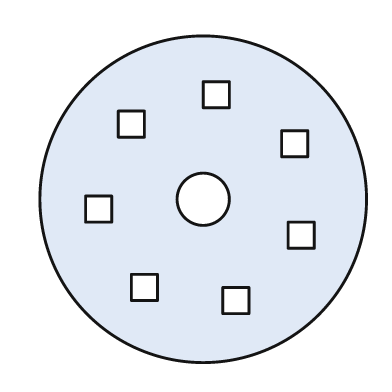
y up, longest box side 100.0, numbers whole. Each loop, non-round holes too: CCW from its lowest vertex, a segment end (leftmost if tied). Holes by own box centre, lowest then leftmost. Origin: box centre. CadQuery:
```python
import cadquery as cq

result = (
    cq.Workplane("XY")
    .moveTo(0.0, 0.0)
    .circle(50.0)
    .moveTo(6.0, -35.0)
    .lineTo(14.0, -35.0)
    .lineTo(14.0, -27.0)
    .lineTo(6.0, -27.0)
    .close()
    .moveTo(-22.0, -31.0)
    .lineTo(-14.0, -31.0)
    .lineTo(-14.0, -23.0)
    .lineTo(-22.0, -23.0)
    .close()
    .moveTo(26.0, -15.0)
    .lineTo(34.0, -15.0)
    .lineTo(34.0, -7.0)
    .lineTo(26.0, -7.0)
    .close()
    .moveTo(-36.0, -7.0)
    .lineTo(-28.0, -7.0)
    .lineTo(-28.0, 1.0)
    .lineTo(-36.0, 1.0)
    .close()
    .moveTo(0.0, 0.0)
    .circle(8.0)
    .moveTo(24.0, 13.0)
    .lineTo(32.0, 13.0)
    .lineTo(32.0, 21.0)
    .lineTo(24.0, 21.0)
    .close()
    .moveTo(-26.0, 19.0)
    .lineTo(-18.0, 19.0)
    .lineTo(-18.0, 27.0)
    .lineTo(-26.0, 27.0)
    .close()
    .moveTo(0.0, 28.0)
    .lineTo(8.0, 28.0)
    .lineTo(8.0, 36.0)
    .lineTo(0.0, 36.0)
    .close()
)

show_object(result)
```